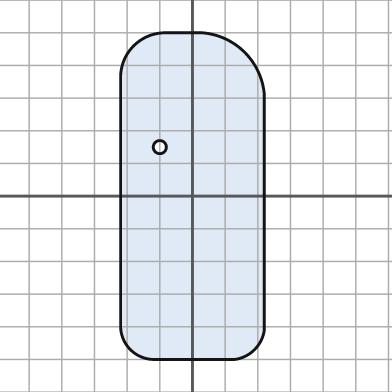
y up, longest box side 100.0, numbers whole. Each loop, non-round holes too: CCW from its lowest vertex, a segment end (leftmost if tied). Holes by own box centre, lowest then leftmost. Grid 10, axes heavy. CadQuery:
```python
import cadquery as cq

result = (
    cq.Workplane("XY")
    .moveTo(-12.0, -50.0)
    .lineTo(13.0, -50.0)
    .threePointArc((19.0, -47.0), (22.0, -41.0))
    .lineTo(22.0, 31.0)
    .threePointArc((16.0, 44.0), (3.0, 50.0))
    .lineTo(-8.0, 50.0)
    .threePointArc((-18.0, 46.0), (-22.0, 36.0))
    .lineTo(-22.0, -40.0)
    .threePointArc((-19.0, -47.0), (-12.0, -50.0))
    .close()
    .moveTo(-10.0, 15.0)
    .circle(2.0)
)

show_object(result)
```